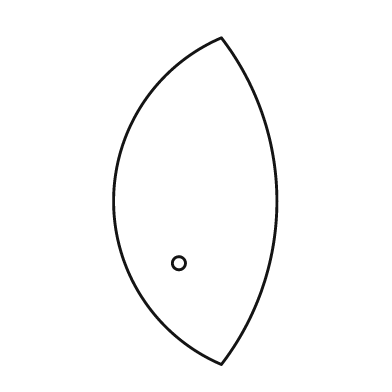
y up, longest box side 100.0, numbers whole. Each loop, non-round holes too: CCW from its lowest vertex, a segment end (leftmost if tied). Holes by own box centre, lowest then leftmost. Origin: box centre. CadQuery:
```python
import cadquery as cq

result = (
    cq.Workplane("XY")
    .moveTo(8.0, -50.0)
    .threePointArc((25.0, 0.0), (8.0, 50.0))
    .threePointArc((-25.0, 0.0), (8.0, -50.0))
    .close()
    .moveTo(-5.0, -19.0)
    .circle(2.0)
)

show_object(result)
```